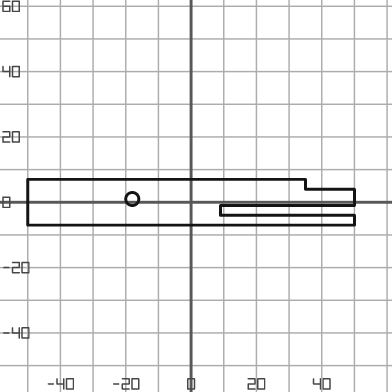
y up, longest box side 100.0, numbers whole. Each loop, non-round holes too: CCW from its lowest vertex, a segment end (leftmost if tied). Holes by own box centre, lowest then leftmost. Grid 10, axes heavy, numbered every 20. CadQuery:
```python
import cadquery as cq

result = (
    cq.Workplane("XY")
    .moveTo(-50.0, -7.0)
    .lineTo(50.0, -7.0)
    .lineTo(50.0, -4.0)
    .lineTo(9.0, -4.0)
    .lineTo(9.0, -1.0)
    .lineTo(50.0, -1.0)
    .lineTo(50.0, 4.0)
    .lineTo(35.0, 4.0)
    .lineTo(35.0, 7.0)
    .lineTo(-50.0, 7.0)
    .close()
    .moveTo(-18.0, 1.0)
    .circle(2.0)
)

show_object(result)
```